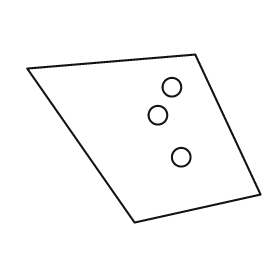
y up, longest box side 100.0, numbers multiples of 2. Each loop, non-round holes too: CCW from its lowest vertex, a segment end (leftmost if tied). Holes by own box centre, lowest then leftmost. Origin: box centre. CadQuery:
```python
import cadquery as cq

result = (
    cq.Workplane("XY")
    .moveTo(-4.0, -36.0)
    .lineTo(50.0, -24.0)
    .lineTo(22.0, 36.0)
    .lineTo(-50.0, 30.0)
    .close()
    .moveTo(16.0, -8.0)
    .circle(4.0)
    .moveTo(6.0, 10.0)
    .circle(4.0)
    .moveTo(12.0, 22.0)
    .circle(4.0)
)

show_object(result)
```